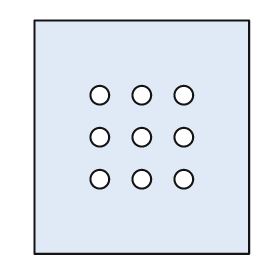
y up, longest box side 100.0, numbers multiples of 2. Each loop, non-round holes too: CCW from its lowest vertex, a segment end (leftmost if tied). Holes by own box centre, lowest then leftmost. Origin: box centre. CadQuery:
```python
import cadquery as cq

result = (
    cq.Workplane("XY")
    .moveTo(-46.0, -50.0)
    .lineTo(46.0, -50.0)
    .lineTo(46.0, 50.0)
    .lineTo(-46.0, 50.0)
    .close()
    .moveTo(-18.0, -18.0)
    .circle(4.0)
    .moveTo(0.0, -18.0)
    .circle(4.0)
    .moveTo(18.0, -18.0)
    .circle(4.0)
    .moveTo(-18.0, 0.0)
    .circle(4.0)
    .moveTo(0.0, 0.0)
    .circle(4.0)
    .moveTo(18.0, 0.0)
    .circle(4.0)
    .moveTo(-18.0, 18.0)
    .circle(4.0)
    .moveTo(0.0, 18.0)
    .circle(4.0)
    .moveTo(18.0, 18.0)
    .circle(4.0)
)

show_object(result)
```